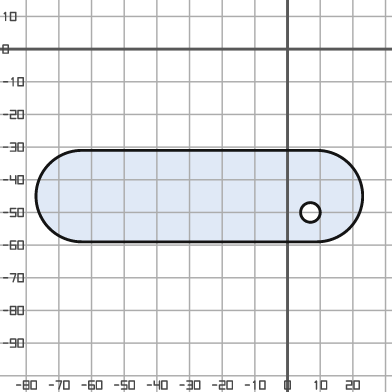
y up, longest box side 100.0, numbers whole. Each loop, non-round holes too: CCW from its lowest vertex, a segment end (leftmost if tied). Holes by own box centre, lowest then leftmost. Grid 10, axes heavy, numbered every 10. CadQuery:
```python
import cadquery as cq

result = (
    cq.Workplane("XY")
    .moveTo(-63.0, -59.0)
    .lineTo(9.0, -59.0)
    .threePointArc((23.0, -45.0), (9.0, -31.0))
    .lineTo(-63.0, -31.0)
    .threePointArc((-77.0, -45.0), (-63.0, -59.0))
    .close()
    .moveTo(7.0, -50.0)
    .circle(3.0)
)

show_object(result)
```